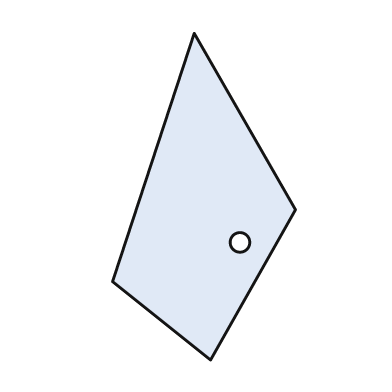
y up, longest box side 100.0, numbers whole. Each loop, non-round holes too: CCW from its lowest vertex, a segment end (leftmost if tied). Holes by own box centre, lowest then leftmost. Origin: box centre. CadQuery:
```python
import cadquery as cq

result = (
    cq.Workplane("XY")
    .moveTo(2.0, -50.0)
    .lineTo(28.0, -4.0)
    .lineTo(-3.0, 50.0)
    .lineTo(-28.0, -26.0)
    .close()
    .moveTo(11.0, -14.0)
    .circle(3.0)
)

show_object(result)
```